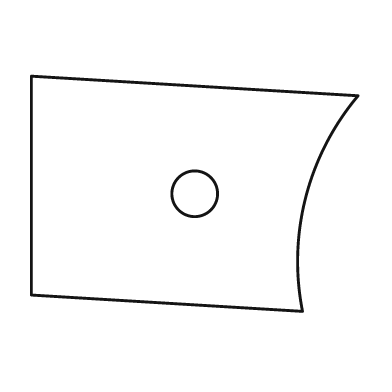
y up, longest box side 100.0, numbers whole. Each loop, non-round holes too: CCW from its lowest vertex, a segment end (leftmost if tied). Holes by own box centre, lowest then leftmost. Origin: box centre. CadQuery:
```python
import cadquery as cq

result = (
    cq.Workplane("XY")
    .moveTo(33.0, -36.0)
    .threePointArc((34.0, -1.0), (50.0, 30.0))
    .lineTo(-50.0, 36.0)
    .lineTo(-50.0, -31.0)
    .close()
    .moveTo(0.0, 0.0)
    .circle(7.0)
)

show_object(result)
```